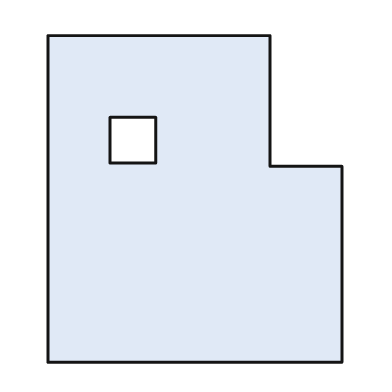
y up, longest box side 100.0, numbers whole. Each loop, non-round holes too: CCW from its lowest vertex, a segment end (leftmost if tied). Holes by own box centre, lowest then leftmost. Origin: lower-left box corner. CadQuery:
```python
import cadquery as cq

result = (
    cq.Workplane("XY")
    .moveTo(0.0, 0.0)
    .lineTo(90.0, 0.0)
    .lineTo(90.0, 60.0)
    .lineTo(68.0, 60.0)
    .lineTo(68.0, 100.0)
    .lineTo(0.0, 100.0)
    .close()
    .moveTo(19.0, 61.0)
    .lineTo(33.0, 61.0)
    .lineTo(33.0, 75.0)
    .lineTo(19.0, 75.0)
    .close()
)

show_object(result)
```